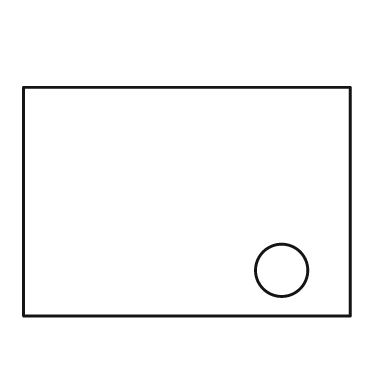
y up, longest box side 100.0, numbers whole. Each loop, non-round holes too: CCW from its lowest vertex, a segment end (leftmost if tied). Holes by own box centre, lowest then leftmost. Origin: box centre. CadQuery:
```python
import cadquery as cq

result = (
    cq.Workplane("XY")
    .moveTo(-50.0, -35.0)
    .lineTo(50.0, -35.0)
    .lineTo(50.0, 35.0)
    .lineTo(-50.0, 35.0)
    .close()
    .moveTo(29.0, -21.0)
    .circle(8.0)
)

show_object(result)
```